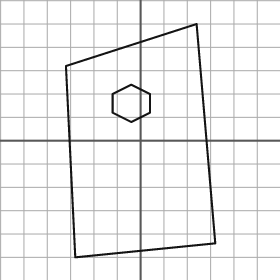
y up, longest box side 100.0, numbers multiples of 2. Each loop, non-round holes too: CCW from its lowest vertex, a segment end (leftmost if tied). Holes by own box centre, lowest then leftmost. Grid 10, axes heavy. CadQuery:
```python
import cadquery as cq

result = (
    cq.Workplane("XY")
    .moveTo(-28.0, -50.0)
    .lineTo(32.0, -44.0)
    .lineTo(24.0, 50.0)
    .lineTo(-32.0, 32.0)
    .close()
    .moveTo(-4.0, 8.0)
    .lineTo(4.0, 12.0)
    .lineTo(4.0, 20.0)
    .lineTo(-4.0, 24.0)
    .lineTo(-12.0, 20.0)
    .lineTo(-12.0, 12.0)
    .close()
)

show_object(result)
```